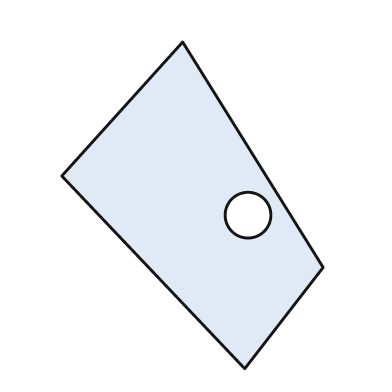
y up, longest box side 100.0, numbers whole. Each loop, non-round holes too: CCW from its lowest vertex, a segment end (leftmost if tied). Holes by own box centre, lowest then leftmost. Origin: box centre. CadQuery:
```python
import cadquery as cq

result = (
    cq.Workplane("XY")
    .moveTo(16.0, -50.0)
    .lineTo(40.0, -19.0)
    .lineTo(-3.0, 50.0)
    .lineTo(-40.0, 9.0)
    .close()
    .moveTo(17.0, -3.0)
    .circle(7.0)
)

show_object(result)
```